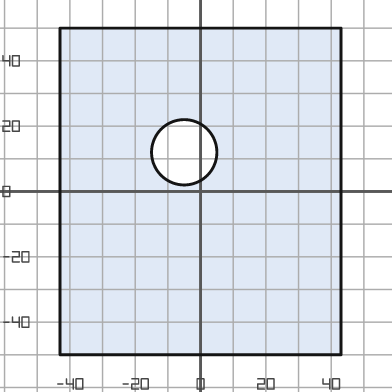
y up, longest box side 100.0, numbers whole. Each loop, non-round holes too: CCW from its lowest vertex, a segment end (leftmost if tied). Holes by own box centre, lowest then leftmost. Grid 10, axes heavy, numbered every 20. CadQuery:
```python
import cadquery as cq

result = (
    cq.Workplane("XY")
    .moveTo(-43.0, -50.0)
    .lineTo(43.0, -50.0)
    .lineTo(43.0, 50.0)
    .lineTo(-43.0, 50.0)
    .close()
    .moveTo(-5.0, 12.0)
    .circle(10.0)
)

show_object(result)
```